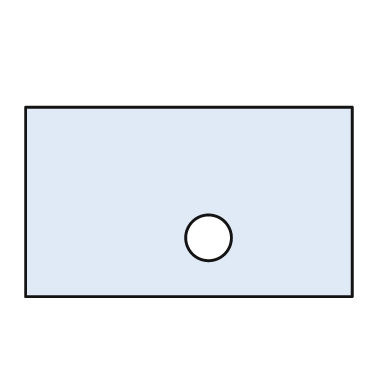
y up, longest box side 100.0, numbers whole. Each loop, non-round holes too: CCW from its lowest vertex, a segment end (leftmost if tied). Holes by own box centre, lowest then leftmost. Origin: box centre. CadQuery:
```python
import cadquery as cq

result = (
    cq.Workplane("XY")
    .moveTo(-50.0, -29.0)
    .lineTo(50.0, -29.0)
    .lineTo(50.0, 29.0)
    .lineTo(-50.0, 29.0)
    .close()
    .moveTo(6.0, -11.0)
    .circle(7.0)
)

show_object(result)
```